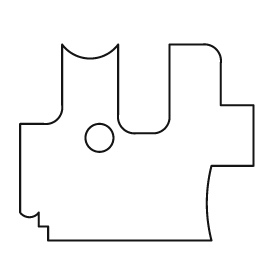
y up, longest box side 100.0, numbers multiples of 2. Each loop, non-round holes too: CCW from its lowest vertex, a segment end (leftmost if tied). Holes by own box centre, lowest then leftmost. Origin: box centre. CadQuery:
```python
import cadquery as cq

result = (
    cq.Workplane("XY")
    .moveTo(-38.0, -42.0)
    .lineTo(32.0, -42.0)
    .threePointArc((30.0, -26.0), (32.0, -10.0))
    .lineTo(50.0, -10.0)
    .lineTo(50.0, 16.0)
    .lineTo(36.0, 16.0)
    .lineTo(36.0, 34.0)
    .threePointArc((34.0, 40.0), (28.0, 42.0))
    .lineTo(14.0, 42.0)
    .lineTo(14.0, 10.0)
    .threePointArc((12.0, 6.0), (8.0, 4.0))
    .lineTo(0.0, 4.0)
    .threePointArc((-6.0, 6.0), (-8.0, 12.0))
    .lineTo(-8.0, 42.0)
    .threePointArc((-20.0, 36.0), (-32.0, 42.0))
    .lineTo(-32.0, 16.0)
    .threePointArc((-34.0, 10.0), (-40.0, 8.0))
    .lineTo(-50.0, 8.0)
    .lineTo(-50.0, -30.0)
    .threePointArc((-46.0, -32.0), (-42.0, -30.0))
    .lineTo(-42.0, -36.0)
    .lineTo(-38.0, -36.0)
    .close()
    .moveTo(-16.0, 2.0)
    .circle(6.0)
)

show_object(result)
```